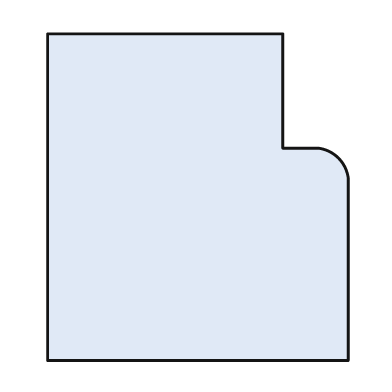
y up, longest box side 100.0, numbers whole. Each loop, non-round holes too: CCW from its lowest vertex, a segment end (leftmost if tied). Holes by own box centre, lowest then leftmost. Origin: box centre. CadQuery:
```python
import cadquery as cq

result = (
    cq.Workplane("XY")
    .moveTo(-46.0, -50.0)
    .lineTo(46.0, -50.0)
    .lineTo(46.0, 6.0)
    .threePointArc((43.0, 12.0), (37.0, 15.0))
    .lineTo(26.0, 15.0)
    .lineTo(26.0, 50.0)
    .lineTo(-46.0, 50.0)
    .close()
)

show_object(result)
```